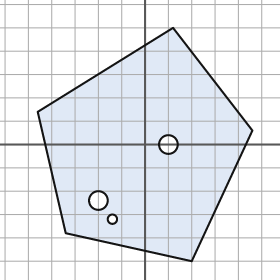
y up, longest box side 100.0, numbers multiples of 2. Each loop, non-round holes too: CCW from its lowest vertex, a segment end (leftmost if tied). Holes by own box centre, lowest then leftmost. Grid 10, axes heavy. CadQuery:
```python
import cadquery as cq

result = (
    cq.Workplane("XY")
    .moveTo(20.0, -50.0)
    .lineTo(46.0, 6.0)
    .lineTo(12.0, 50.0)
    .lineTo(-46.0, 14.0)
    .lineTo(-34.0, -38.0)
    .close()
    .moveTo(-14.0, -32.0)
    .circle(2.0)
    .moveTo(-20.0, -24.0)
    .circle(4.0)
    .moveTo(10.0, 0.0)
    .circle(4.0)
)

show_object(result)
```